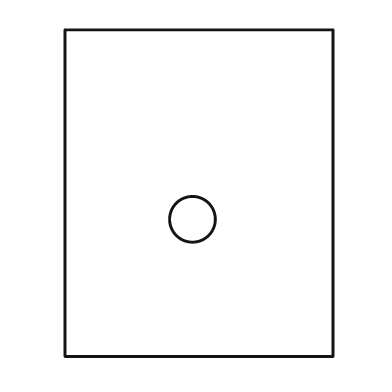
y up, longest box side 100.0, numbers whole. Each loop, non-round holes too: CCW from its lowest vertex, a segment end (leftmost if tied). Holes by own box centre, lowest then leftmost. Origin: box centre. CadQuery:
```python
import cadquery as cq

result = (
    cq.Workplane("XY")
    .moveTo(-41.0, -50.0)
    .lineTo(41.0, -50.0)
    .lineTo(41.0, 50.0)
    .lineTo(-41.0, 50.0)
    .close()
    .moveTo(-2.0, -8.0)
    .circle(7.0)
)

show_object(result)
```